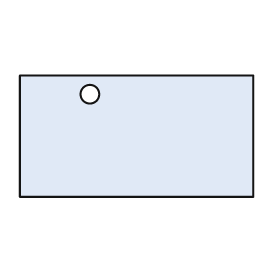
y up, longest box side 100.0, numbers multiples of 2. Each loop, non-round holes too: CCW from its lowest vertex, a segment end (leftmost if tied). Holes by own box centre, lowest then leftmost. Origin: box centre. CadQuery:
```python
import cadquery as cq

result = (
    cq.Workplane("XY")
    .moveTo(-50.0, -26.0)
    .lineTo(50.0, -26.0)
    .lineTo(50.0, 26.0)
    .lineTo(-50.0, 26.0)
    .close()
    .moveTo(-20.0, 18.0)
    .circle(4.0)
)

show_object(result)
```